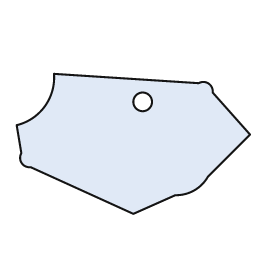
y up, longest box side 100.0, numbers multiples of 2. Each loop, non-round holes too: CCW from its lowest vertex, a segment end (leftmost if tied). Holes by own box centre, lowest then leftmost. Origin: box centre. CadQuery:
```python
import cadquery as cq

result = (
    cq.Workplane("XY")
    .moveTo(0.0, -30.0)
    .lineTo(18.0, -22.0)
    .threePointArc((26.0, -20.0), (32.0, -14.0))
    .lineTo(50.0, 4.0)
    .lineTo(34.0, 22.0)
    .threePointArc((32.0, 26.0), (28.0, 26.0))
    .lineTo(-34.0, 30.0)
    .threePointArc((-38.0, 16.0), (-50.0, 8.0))
    .lineTo(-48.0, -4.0)
    .threePointArc((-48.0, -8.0), (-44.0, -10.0))
    .close()
    .moveTo(4.0, 18.0)
    .circle(4.0)
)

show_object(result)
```